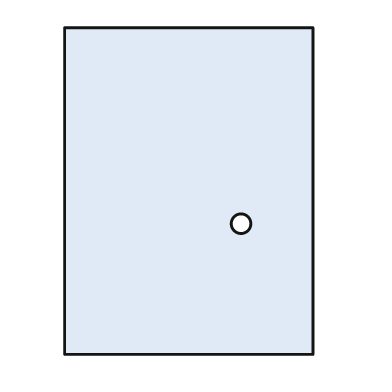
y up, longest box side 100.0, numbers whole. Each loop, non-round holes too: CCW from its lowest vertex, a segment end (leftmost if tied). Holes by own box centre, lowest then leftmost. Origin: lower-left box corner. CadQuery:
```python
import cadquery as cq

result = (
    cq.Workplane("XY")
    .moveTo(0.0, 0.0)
    .lineTo(76.0, 0.0)
    .lineTo(76.0, 100.0)
    .lineTo(0.0, 100.0)
    .close()
    .moveTo(54.0, 40.0)
    .circle(3.0)
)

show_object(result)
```